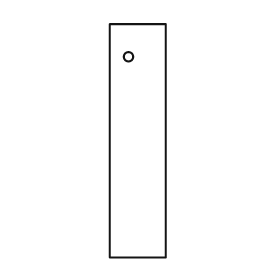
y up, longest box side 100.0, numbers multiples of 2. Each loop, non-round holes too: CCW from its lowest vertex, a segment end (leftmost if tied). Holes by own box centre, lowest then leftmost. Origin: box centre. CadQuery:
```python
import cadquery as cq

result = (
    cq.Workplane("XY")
    .moveTo(-12.0, -50.0)
    .lineTo(12.0, -50.0)
    .lineTo(12.0, 50.0)
    .lineTo(-12.0, 50.0)
    .close()
    .moveTo(-4.0, 36.0)
    .circle(2.0)
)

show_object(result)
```